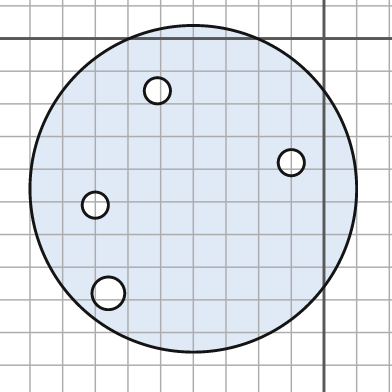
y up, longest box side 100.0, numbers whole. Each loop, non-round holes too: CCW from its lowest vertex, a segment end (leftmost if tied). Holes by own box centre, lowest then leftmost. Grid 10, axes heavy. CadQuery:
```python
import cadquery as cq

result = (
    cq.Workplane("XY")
    .moveTo(-40.0, -46.0)
    .circle(50.0)
    .moveTo(-66.0, -78.0)
    .circle(5.0)
    .moveTo(-70.0, -51.0)
    .circle(4.0)
    .moveTo(-10.0, -38.0)
    .circle(4.0)
    .moveTo(-51.0, -16.0)
    .circle(4.0)
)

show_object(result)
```